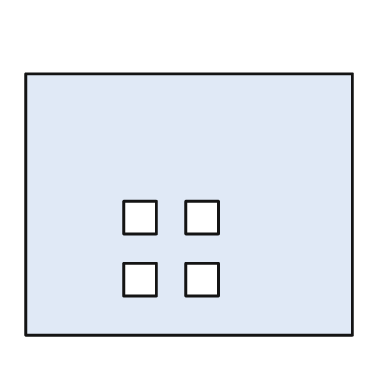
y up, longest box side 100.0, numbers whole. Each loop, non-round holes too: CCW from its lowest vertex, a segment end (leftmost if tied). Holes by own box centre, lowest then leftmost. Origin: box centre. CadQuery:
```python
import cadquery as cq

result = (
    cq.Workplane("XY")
    .moveTo(-50.0, -40.0)
    .lineTo(50.0, -40.0)
    .lineTo(50.0, 40.0)
    .lineTo(-50.0, 40.0)
    .close()
    .moveTo(-20.0, -28.0)
    .lineTo(-10.0, -28.0)
    .lineTo(-10.0, -18.0)
    .lineTo(-20.0, -18.0)
    .close()
    .moveTo(-1.0, -28.0)
    .lineTo(9.0, -28.0)
    .lineTo(9.0, -18.0)
    .lineTo(-1.0, -18.0)
    .close()
    .moveTo(-20.0, -9.0)
    .lineTo(-10.0, -9.0)
    .lineTo(-10.0, 1.0)
    .lineTo(-20.0, 1.0)
    .close()
    .moveTo(-1.0, -9.0)
    .lineTo(9.0, -9.0)
    .lineTo(9.0, 1.0)
    .lineTo(-1.0, 1.0)
    .close()
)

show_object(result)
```